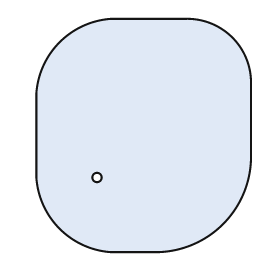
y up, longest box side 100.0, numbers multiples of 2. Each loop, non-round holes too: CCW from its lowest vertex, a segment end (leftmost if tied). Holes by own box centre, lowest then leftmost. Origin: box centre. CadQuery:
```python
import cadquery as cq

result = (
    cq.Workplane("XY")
    .moveTo(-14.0, -50.0)
    .lineTo(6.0, -50.0)
    .threePointArc((34.0, -38.0), (46.0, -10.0))
    .lineTo(46.0, 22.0)
    .threePointArc((38.0, 42.0), (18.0, 50.0))
    .lineTo(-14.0, 50.0)
    .threePointArc((-36.0, 40.0), (-46.0, 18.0))
    .lineTo(-46.0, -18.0)
    .threePointArc((-36.0, -40.0), (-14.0, -50.0))
    .close()
    .moveTo(-20.0, -18.0)
    .circle(2.0)
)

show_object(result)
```